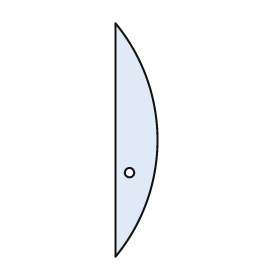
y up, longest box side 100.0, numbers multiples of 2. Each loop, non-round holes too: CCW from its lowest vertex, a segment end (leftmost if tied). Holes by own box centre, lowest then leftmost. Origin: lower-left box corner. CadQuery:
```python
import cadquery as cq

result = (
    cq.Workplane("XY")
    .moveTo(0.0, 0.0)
    .threePointArc((18.0, 50.0), (0.0, 100.0))
    .close()
    .moveTo(6.0, 36.0)
    .circle(2.0)
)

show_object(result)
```